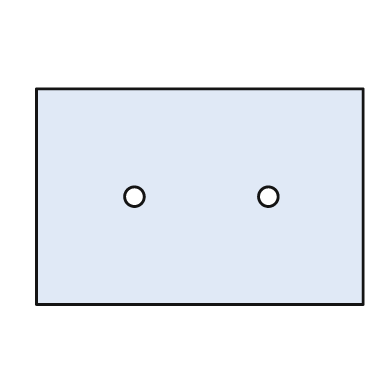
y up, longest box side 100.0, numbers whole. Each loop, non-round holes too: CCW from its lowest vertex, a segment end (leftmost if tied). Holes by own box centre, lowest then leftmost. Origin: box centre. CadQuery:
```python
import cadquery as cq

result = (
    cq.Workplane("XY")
    .moveTo(-50.0, -33.0)
    .lineTo(50.0, -33.0)
    .lineTo(50.0, 33.0)
    .lineTo(-50.0, 33.0)
    .close()
    .moveTo(-20.0, 0.0)
    .circle(3.0)
    .moveTo(21.0, 0.0)
    .circle(3.0)
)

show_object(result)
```